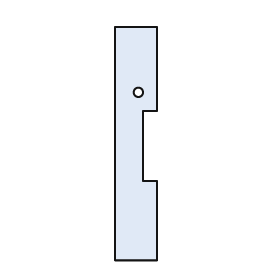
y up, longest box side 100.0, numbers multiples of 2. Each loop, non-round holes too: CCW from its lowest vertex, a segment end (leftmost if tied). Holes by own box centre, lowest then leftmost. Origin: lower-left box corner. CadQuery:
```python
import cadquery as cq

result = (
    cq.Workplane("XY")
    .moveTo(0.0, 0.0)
    .lineTo(18.0, 0.0)
    .lineTo(18.0, 34.0)
    .lineTo(12.0, 34.0)
    .lineTo(12.0, 64.0)
    .lineTo(18.0, 64.0)
    .lineTo(18.0, 100.0)
    .lineTo(0.0, 100.0)
    .close()
    .moveTo(10.0, 72.0)
    .circle(2.0)
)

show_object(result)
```